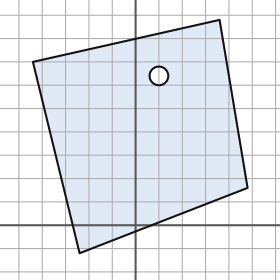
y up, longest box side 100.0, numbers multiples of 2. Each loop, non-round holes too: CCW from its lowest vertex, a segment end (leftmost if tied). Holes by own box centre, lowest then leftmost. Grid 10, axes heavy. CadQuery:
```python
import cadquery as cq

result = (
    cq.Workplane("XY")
    .moveTo(-24.0, -12.0)
    .lineTo(48.0, 16.0)
    .lineTo(36.0, 88.0)
    .lineTo(-44.0, 70.0)
    .close()
    .moveTo(10.0, 64.0)
    .circle(4.0)
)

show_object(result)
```